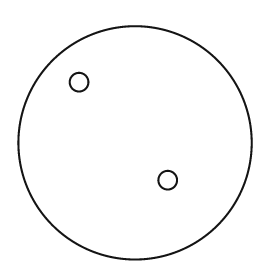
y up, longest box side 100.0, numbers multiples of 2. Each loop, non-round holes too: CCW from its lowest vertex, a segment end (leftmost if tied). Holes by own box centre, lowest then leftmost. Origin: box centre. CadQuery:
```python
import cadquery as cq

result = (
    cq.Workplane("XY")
    .moveTo(0.0, 0.0)
    .circle(50.0)
    .moveTo(14.0, -16.0)
    .circle(4.0)
    .moveTo(-24.0, 26.0)
    .circle(4.0)
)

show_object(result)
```